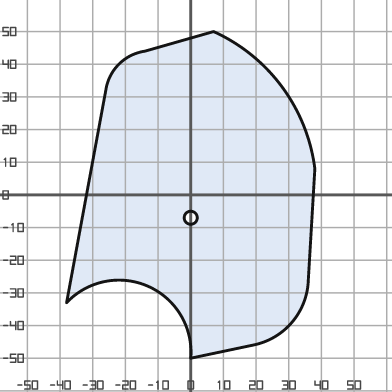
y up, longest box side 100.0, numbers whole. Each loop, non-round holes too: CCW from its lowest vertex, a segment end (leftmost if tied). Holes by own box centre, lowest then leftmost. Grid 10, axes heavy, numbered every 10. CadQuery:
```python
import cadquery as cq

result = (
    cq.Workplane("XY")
    .moveTo(0.0, -50.0)
    .lineTo(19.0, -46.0)
    .threePointArc((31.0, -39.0), (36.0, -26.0))
    .lineTo(38.0, 8.0)
    .threePointArc((28.0, 33.0), (7.0, 50.0))
    .lineTo(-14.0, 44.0)
    .threePointArc((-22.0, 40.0), (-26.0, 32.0))
    .lineTo(-38.0, -33.0)
    .threePointArc((-13.0, -28.0), (0.0, -50.0))
    .close()
    .moveTo(0.0, -7.0)
    .circle(2.0)
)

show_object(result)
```